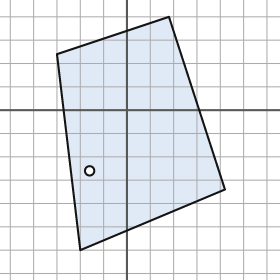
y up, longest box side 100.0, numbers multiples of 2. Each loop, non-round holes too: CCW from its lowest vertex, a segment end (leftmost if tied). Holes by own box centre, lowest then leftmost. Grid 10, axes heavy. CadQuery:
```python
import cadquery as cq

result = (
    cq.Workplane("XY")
    .moveTo(-20.0, -60.0)
    .lineTo(42.0, -34.0)
    .lineTo(18.0, 40.0)
    .lineTo(-30.0, 24.0)
    .close()
    .moveTo(-16.0, -26.0)
    .circle(2.0)
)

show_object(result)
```